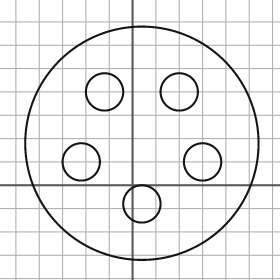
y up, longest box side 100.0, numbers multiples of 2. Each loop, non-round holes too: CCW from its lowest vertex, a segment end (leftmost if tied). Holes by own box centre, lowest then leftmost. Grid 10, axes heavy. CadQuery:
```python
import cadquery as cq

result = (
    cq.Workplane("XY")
    .moveTo(4.0, 18.0)
    .circle(50.0)
    .moveTo(4.0, -8.0)
    .circle(8.0)
    .moveTo(-22.0, 10.0)
    .circle(8.0)
    .moveTo(30.0, 10.0)
    .circle(8.0)
    .moveTo(-12.0, 40.0)
    .circle(8.0)
    .moveTo(20.0, 40.0)
    .circle(8.0)
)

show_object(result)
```